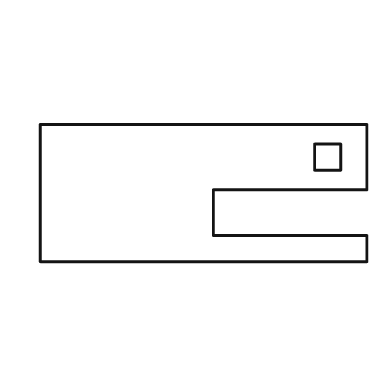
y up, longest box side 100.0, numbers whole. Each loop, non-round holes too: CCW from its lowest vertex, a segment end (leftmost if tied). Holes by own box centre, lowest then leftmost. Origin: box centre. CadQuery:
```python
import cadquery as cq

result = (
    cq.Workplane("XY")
    .moveTo(-50.0, -21.0)
    .lineTo(50.0, -21.0)
    .lineTo(50.0, -13.0)
    .lineTo(3.0, -13.0)
    .lineTo(3.0, 1.0)
    .lineTo(50.0, 1.0)
    .lineTo(50.0, 21.0)
    .lineTo(-50.0, 21.0)
    .close()
    .moveTo(34.0, 7.0)
    .lineTo(42.0, 7.0)
    .lineTo(42.0, 15.0)
    .lineTo(34.0, 15.0)
    .close()
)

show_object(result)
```